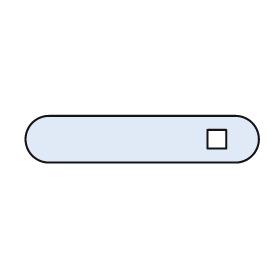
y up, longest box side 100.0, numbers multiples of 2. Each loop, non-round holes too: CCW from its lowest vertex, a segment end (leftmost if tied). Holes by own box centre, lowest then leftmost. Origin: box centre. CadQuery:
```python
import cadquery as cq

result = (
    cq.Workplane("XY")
    .moveTo(-40.0, -10.0)
    .lineTo(40.0, -10.0)
    .threePointArc((50.0, 0.0), (40.0, 10.0))
    .lineTo(-40.0, 10.0)
    .threePointArc((-50.0, 0.0), (-40.0, -10.0))
    .close()
    .moveTo(28.0, -4.0)
    .lineTo(36.0, -4.0)
    .lineTo(36.0, 4.0)
    .lineTo(28.0, 4.0)
    .close()
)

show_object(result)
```